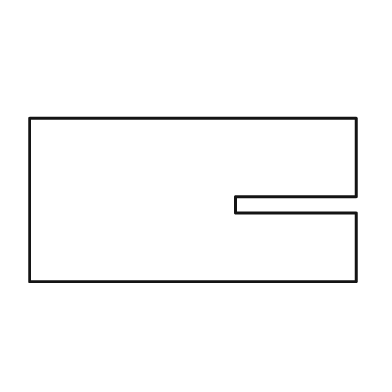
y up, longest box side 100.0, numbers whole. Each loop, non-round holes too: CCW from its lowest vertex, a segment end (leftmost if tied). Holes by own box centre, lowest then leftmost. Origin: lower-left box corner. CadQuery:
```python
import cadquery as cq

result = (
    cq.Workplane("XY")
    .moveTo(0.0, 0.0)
    .lineTo(100.0, 0.0)
    .lineTo(100.0, 21.0)
    .lineTo(63.0, 21.0)
    .lineTo(63.0, 26.0)
    .lineTo(100.0, 26.0)
    .lineTo(100.0, 50.0)
    .lineTo(0.0, 50.0)
    .close()
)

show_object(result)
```